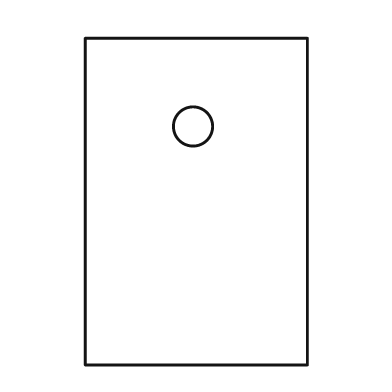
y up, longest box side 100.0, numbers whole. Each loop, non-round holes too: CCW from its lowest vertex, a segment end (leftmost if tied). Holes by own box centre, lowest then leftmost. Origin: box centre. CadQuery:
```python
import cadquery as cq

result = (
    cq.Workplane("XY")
    .moveTo(-34.0, -50.0)
    .lineTo(34.0, -50.0)
    .lineTo(34.0, 50.0)
    .lineTo(-34.0, 50.0)
    .close()
    .moveTo(-1.0, 23.0)
    .circle(6.0)
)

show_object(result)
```